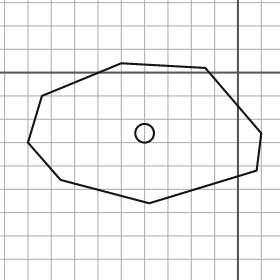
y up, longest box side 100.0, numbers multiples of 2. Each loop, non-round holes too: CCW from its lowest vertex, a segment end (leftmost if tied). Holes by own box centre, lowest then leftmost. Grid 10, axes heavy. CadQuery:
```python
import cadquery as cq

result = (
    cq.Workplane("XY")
    .moveTo(-38.0, -56.0)
    .lineTo(8.0, -42.0)
    .lineTo(10.0, -26.0)
    .lineTo(-14.0, 2.0)
    .lineTo(-50.0, 4.0)
    .lineTo(-84.0, -10.0)
    .lineTo(-90.0, -30.0)
    .lineTo(-76.0, -46.0)
    .close()
    .moveTo(-40.0, -26.0)
    .circle(4.0)
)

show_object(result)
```